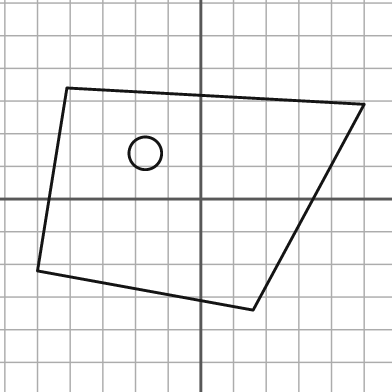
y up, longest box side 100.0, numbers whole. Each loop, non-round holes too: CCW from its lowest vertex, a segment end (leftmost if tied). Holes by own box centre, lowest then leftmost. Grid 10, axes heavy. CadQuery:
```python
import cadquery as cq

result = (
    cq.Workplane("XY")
    .moveTo(16.0, -34.0)
    .lineTo(50.0, 29.0)
    .lineTo(-41.0, 34.0)
    .lineTo(-50.0, -22.0)
    .close()
    .moveTo(-17.0, 14.0)
    .circle(5.0)
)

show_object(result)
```